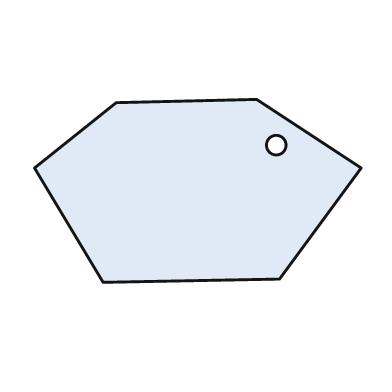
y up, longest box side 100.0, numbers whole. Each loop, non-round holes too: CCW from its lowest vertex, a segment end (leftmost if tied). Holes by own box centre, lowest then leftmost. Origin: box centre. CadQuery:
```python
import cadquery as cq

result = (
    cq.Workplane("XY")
    .moveTo(-29.0, -28.0)
    .lineTo(25.0, -27.0)
    .lineTo(50.0, 7.0)
    .lineTo(18.0, 28.0)
    .lineTo(-25.0, 27.0)
    .lineTo(-50.0, 7.0)
    .close()
    .moveTo(24.0, 14.0)
    .circle(3.0)
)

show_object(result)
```